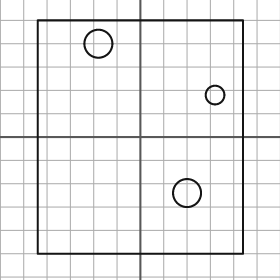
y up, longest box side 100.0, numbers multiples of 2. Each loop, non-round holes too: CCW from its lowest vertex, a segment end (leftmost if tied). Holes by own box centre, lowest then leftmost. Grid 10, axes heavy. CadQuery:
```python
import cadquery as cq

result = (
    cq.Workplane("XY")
    .moveTo(-44.0, -50.0)
    .lineTo(44.0, -50.0)
    .lineTo(44.0, 50.0)
    .lineTo(-44.0, 50.0)
    .close()
    .moveTo(20.0, -24.0)
    .circle(6.0)
    .moveTo(32.0, 18.0)
    .circle(4.0)
    .moveTo(-18.0, 40.0)
    .circle(6.0)
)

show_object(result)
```